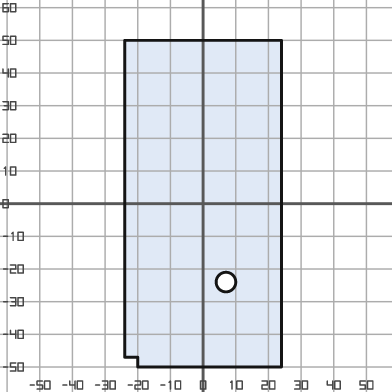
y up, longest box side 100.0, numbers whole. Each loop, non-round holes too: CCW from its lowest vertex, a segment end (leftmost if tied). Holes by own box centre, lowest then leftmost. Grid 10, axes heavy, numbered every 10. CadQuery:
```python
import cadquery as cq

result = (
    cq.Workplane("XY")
    .moveTo(-20.0, -50.0)
    .lineTo(24.0, -50.0)
    .lineTo(24.0, 50.0)
    .lineTo(-24.0, 50.0)
    .lineTo(-24.0, -47.0)
    .lineTo(-20.0, -47.0)
    .close()
    .moveTo(7.0, -24.0)
    .circle(3.0)
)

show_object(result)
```